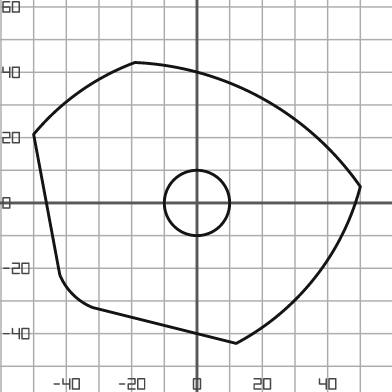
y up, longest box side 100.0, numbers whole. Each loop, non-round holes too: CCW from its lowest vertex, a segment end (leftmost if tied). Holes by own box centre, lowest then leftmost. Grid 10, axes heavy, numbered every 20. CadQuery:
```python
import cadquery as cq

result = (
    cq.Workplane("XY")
    .moveTo(12.0, -43.0)
    .threePointArc((36.0, -23.0), (50.0, 5.0))
    .threePointArc((20.0, 32.0), (-19.0, 43.0))
    .threePointArc((-36.0, 34.0), (-50.0, 21.0))
    .lineTo(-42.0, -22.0)
    .threePointArc((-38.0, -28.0), (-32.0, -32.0))
    .close()
    .moveTo(0.0, 0.0)
    .circle(10.0)
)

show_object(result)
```